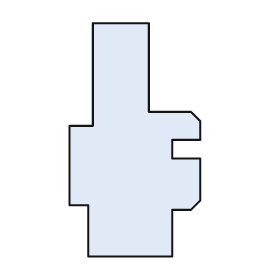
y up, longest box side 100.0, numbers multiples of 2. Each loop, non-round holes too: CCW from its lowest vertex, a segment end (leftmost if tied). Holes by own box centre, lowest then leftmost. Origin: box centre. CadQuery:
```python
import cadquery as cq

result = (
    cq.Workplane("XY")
    .moveTo(-20.0, -50.0)
    .lineTo(16.0, -50.0)
    .lineTo(16.0, -30.0)
    .lineTo(24.0, -30.0)
    .lineTo(28.0, -26.0)
    .lineTo(28.0, -8.0)
    .lineTo(16.0, -8.0)
    .lineTo(16.0, 0.0)
    .lineTo(28.0, 0.0)
    .lineTo(28.0, 8.0)
    .lineTo(24.0, 12.0)
    .lineTo(6.0, 12.0)
    .lineTo(6.0, 50.0)
    .lineTo(-18.0, 50.0)
    .lineTo(-18.0, 6.0)
    .lineTo(-28.0, 6.0)
    .lineTo(-28.0, -28.0)
    .lineTo(-20.0, -28.0)
    .close()
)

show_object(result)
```